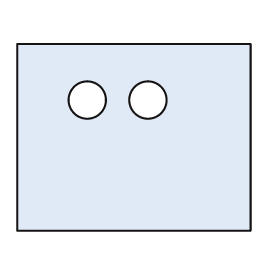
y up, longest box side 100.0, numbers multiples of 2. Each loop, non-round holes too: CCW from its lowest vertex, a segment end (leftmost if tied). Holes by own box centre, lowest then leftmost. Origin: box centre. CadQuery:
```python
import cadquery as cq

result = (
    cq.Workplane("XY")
    .moveTo(-50.0, -40.0)
    .lineTo(50.0, -40.0)
    .lineTo(50.0, 40.0)
    .lineTo(-50.0, 40.0)
    .close()
    .moveTo(-20.0, 16.0)
    .circle(8.0)
    .moveTo(6.0, 16.0)
    .circle(8.0)
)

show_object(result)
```